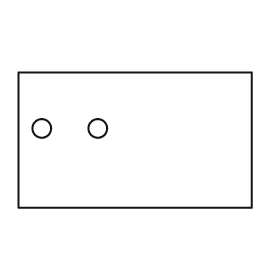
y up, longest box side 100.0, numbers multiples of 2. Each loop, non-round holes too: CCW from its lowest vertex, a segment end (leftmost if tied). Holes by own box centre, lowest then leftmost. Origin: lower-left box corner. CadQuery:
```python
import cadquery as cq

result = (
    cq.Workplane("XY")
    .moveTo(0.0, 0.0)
    .lineTo(100.0, 0.0)
    .lineTo(100.0, 58.0)
    .lineTo(0.0, 58.0)
    .close()
    .moveTo(10.0, 34.0)
    .circle(4.0)
    .moveTo(34.0, 34.0)
    .circle(4.0)
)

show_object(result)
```